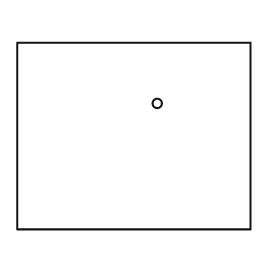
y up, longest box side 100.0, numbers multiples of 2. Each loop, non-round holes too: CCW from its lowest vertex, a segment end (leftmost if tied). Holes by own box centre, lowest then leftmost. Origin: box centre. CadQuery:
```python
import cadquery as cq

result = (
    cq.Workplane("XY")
    .moveTo(-50.0, -40.0)
    .lineTo(50.0, -40.0)
    .lineTo(50.0, 40.0)
    .lineTo(-50.0, 40.0)
    .close()
    .moveTo(10.0, 14.0)
    .circle(2.0)
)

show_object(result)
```